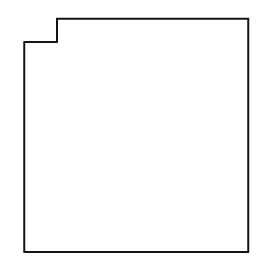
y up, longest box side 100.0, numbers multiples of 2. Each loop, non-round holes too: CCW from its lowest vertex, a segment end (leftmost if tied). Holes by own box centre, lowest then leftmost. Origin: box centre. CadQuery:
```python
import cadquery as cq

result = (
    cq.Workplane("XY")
    .moveTo(-48.0, -50.0)
    .lineTo(48.0, -50.0)
    .lineTo(48.0, 50.0)
    .lineTo(-34.0, 50.0)
    .lineTo(-34.0, 40.0)
    .lineTo(-48.0, 40.0)
    .close()
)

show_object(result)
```